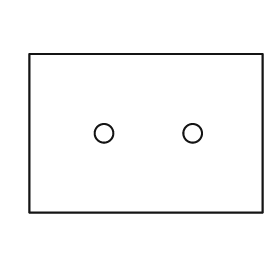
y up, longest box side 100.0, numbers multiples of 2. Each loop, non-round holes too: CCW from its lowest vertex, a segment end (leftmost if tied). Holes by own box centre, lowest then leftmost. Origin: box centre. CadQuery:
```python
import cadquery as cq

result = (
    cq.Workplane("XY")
    .moveTo(-50.0, -34.0)
    .lineTo(50.0, -34.0)
    .lineTo(50.0, 34.0)
    .lineTo(-50.0, 34.0)
    .close()
    .moveTo(-18.0, 0.0)
    .circle(4.0)
    .moveTo(20.0, 0.0)
    .circle(4.0)
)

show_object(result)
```